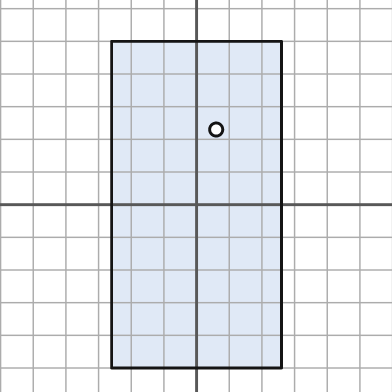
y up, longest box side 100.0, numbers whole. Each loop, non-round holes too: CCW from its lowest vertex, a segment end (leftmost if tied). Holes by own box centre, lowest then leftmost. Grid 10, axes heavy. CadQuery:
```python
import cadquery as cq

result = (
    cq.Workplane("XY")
    .moveTo(-26.0, -50.0)
    .lineTo(26.0, -50.0)
    .lineTo(26.0, 50.0)
    .lineTo(-26.0, 50.0)
    .close()
    .moveTo(6.0, 23.0)
    .circle(2.0)
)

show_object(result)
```